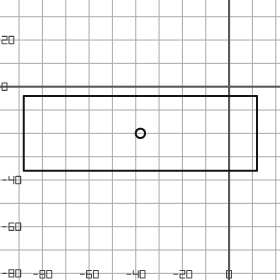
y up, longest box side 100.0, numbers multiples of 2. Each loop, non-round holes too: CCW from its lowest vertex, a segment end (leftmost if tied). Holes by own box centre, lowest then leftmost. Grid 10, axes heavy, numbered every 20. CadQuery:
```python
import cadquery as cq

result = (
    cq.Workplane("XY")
    .moveTo(-88.0, -36.0)
    .lineTo(12.0, -36.0)
    .lineTo(12.0, -4.0)
    .lineTo(-88.0, -4.0)
    .close()
    .moveTo(-38.0, -20.0)
    .circle(2.0)
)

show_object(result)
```